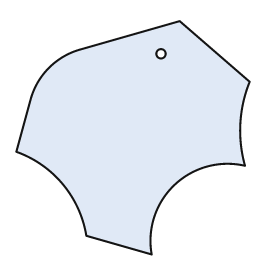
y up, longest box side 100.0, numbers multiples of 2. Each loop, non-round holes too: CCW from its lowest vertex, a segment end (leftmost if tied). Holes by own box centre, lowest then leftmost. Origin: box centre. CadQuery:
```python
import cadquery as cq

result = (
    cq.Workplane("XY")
    .moveTo(8.0, -50.0)
    .threePointArc((18.0, -20.0), (48.0, -12.0))
    .threePointArc((46.0, 6.0), (50.0, 24.0))
    .lineTo(20.0, 50.0)
    .lineTo(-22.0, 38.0)
    .threePointArc((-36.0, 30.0), (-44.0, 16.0))
    .lineTo(-50.0, -6.0)
    .threePointArc((-30.0, -20.0), (-20.0, -42.0))
    .close()
    .moveTo(12.0, 36.0)
    .circle(2.0)
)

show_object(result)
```